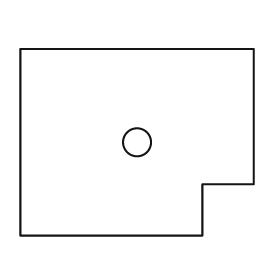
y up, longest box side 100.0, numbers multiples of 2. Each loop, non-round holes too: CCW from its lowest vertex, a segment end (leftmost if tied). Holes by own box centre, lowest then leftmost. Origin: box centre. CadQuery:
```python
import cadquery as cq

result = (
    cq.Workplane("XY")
    .moveTo(-50.0, -40.0)
    .lineTo(28.0, -40.0)
    .lineTo(28.0, -18.0)
    .lineTo(50.0, -18.0)
    .lineTo(50.0, 40.0)
    .lineTo(-50.0, 40.0)
    .close()
    .moveTo(0.0, 0.0)
    .circle(6.0)
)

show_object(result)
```